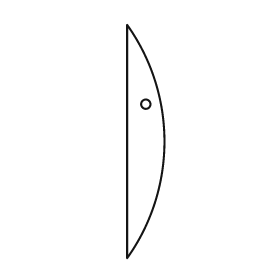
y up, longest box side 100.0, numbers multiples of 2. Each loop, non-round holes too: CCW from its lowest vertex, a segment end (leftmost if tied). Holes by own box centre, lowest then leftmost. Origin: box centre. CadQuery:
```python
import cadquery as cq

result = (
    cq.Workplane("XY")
    .moveTo(-8.0, -50.0)
    .threePointArc((8.0, 0.0), (-8.0, 50.0))
    .close()
    .moveTo(0.0, 16.0)
    .circle(2.0)
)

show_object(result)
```